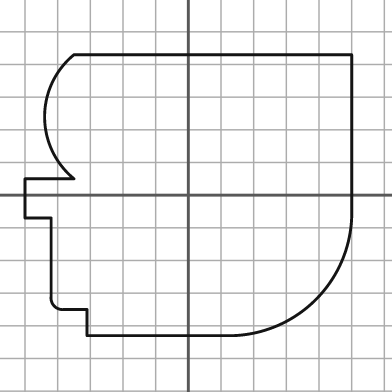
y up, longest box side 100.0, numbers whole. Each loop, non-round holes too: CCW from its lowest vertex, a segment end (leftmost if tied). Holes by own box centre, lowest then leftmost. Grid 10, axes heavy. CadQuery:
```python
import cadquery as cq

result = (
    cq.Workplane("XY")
    .moveTo(-31.0, -43.0)
    .lineTo(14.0, -43.0)
    .threePointArc((39.0, -32.0), (50.0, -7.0))
    .lineTo(50.0, 43.0)
    .lineTo(-35.0, 43.0)
    .threePointArc((-44.0, 24.0), (-35.0, 5.0))
    .lineTo(-50.0, 5.0)
    .lineTo(-50.0, -7.0)
    .lineTo(-42.0, -7.0)
    .lineTo(-42.0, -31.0)
    .threePointArc((-41.0, -34.0), (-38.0, -35.0))
    .lineTo(-31.0, -35.0)
    .close()
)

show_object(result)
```